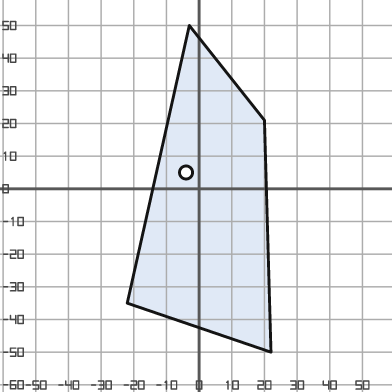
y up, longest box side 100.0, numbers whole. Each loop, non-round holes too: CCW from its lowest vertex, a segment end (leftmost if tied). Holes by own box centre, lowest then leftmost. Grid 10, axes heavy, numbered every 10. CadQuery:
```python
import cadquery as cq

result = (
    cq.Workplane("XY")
    .moveTo(22.0, -50.0)
    .lineTo(20.0, 21.0)
    .lineTo(-3.0, 50.0)
    .lineTo(-22.0, -35.0)
    .close()
    .moveTo(-4.0, 5.0)
    .circle(2.0)
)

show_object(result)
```